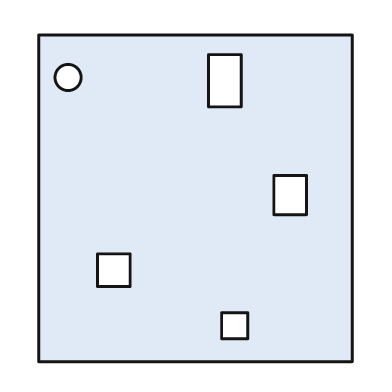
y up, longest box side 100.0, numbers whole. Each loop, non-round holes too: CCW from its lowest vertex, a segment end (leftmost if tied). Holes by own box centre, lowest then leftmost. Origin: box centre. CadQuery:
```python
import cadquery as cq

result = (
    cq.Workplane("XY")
    .moveTo(-48.0, -50.0)
    .lineTo(48.0, -50.0)
    .lineTo(48.0, 50.0)
    .lineTo(-48.0, 50.0)
    .close()
    .moveTo(8.0, -43.0)
    .lineTo(16.0, -43.0)
    .lineTo(16.0, -35.0)
    .lineTo(8.0, -35.0)
    .close()
    .moveTo(-30.0, -27.0)
    .lineTo(-20.0, -27.0)
    .lineTo(-20.0, -17.0)
    .lineTo(-30.0, -17.0)
    .close()
    .moveTo(24.0, -5.0)
    .lineTo(34.0, -5.0)
    .lineTo(34.0, 7.0)
    .lineTo(24.0, 7.0)
    .close()
    .moveTo(4.0, 28.0)
    .lineTo(14.0, 28.0)
    .lineTo(14.0, 44.0)
    .lineTo(4.0, 44.0)
    .close()
    .moveTo(-39.0, 37.0)
    .circle(4.0)
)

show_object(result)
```